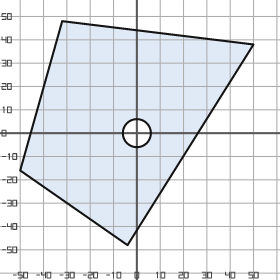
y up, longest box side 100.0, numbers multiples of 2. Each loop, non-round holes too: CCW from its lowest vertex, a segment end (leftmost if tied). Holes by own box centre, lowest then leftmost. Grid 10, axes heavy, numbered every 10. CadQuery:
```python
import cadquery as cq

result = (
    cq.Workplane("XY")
    .moveTo(-4.0, -48.0)
    .lineTo(50.0, 38.0)
    .lineTo(-32.0, 48.0)
    .lineTo(-50.0, -16.0)
    .close()
    .moveTo(0.0, 0.0)
    .circle(6.0)
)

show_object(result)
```